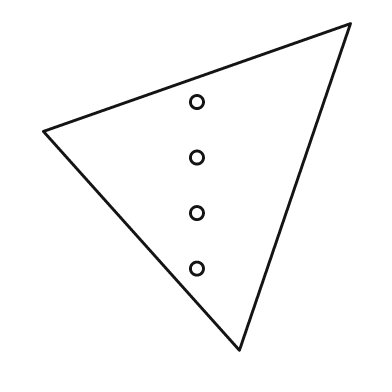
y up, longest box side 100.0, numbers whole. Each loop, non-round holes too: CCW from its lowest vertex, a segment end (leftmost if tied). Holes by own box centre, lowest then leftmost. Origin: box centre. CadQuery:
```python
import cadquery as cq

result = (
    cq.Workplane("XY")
    .moveTo(13.0, -50.0)
    .lineTo(47.0, 50.0)
    .lineTo(-47.0, 17.0)
    .close()
    .moveTo(0.0, -25.0)
    .circle(2.0)
    .moveTo(0.0, -8.0)
    .circle(2.0)
    .moveTo(0.0, 9.0)
    .circle(2.0)
    .moveTo(0.0, 26.0)
    .circle(2.0)
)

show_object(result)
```